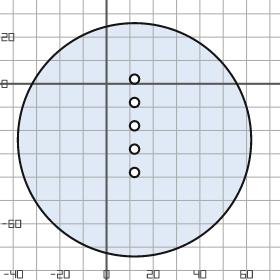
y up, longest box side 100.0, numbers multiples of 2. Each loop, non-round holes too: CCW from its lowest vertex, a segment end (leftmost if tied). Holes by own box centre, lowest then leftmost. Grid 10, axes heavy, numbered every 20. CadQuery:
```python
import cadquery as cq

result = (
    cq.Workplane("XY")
    .moveTo(12.0, -24.0)
    .circle(50.0)
    .moveTo(12.0, -38.0)
    .circle(2.0)
    .moveTo(12.0, -28.0)
    .circle(2.0)
    .moveTo(12.0, -18.0)
    .circle(2.0)
    .moveTo(12.0, -8.0)
    .circle(2.0)
    .moveTo(12.0, 2.0)
    .circle(2.0)
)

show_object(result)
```